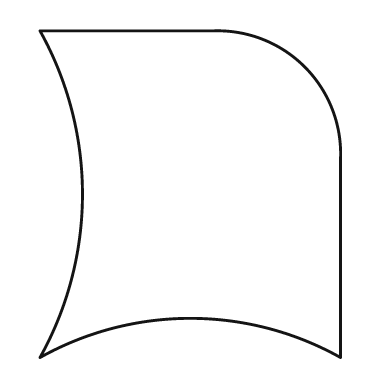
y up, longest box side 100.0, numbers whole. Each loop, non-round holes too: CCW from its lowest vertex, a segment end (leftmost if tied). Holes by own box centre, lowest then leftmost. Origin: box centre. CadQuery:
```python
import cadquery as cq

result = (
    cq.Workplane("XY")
    .moveTo(-46.0, -50.0)
    .threePointArc((0.0, -38.0), (46.0, -50.0))
    .lineTo(46.0, 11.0)
    .threePointArc((35.0, 39.0), (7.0, 50.0))
    .lineTo(-46.0, 50.0)
    .threePointArc((-33.0, 0.0), (-46.0, -50.0))
    .close()
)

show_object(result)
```